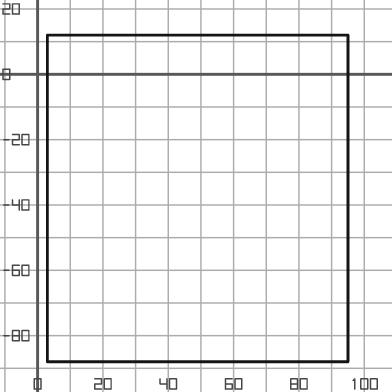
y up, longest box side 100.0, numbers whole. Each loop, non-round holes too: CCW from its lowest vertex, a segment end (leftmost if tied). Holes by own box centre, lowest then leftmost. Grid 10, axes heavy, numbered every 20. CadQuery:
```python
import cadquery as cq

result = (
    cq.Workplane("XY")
    .moveTo(3.0, -88.0)
    .lineTo(95.0, -88.0)
    .lineTo(95.0, 12.0)
    .lineTo(3.0, 12.0)
    .close()
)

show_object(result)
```